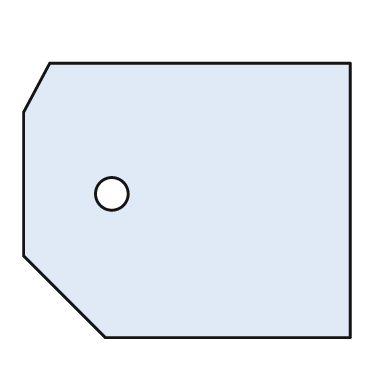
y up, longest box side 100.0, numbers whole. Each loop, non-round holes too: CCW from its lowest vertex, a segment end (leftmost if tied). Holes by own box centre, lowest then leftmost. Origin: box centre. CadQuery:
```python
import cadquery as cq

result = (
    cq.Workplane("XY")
    .moveTo(-25.0, -42.0)
    .lineTo(50.0, -42.0)
    .lineTo(50.0, 42.0)
    .lineTo(-42.0, 42.0)
    .lineTo(-50.0, 27.0)
    .lineTo(-50.0, -17.0)
    .close()
    .moveTo(-23.0, 2.0)
    .circle(5.0)
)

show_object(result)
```